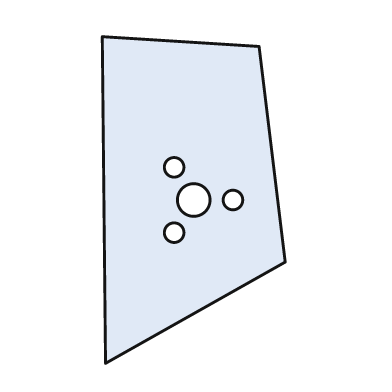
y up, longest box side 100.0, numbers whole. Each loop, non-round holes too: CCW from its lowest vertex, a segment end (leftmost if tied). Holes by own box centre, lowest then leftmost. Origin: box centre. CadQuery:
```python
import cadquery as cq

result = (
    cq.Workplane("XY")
    .moveTo(-27.0, -50.0)
    .lineTo(28.0, -19.0)
    .lineTo(20.0, 47.0)
    .lineTo(-28.0, 50.0)
    .close()
    .moveTo(-6.0, -10.0)
    .circle(3.0)
    .moveTo(0.0, 0.0)
    .circle(5.0)
    .moveTo(12.0, 0.0)
    .circle(3.0)
    .moveTo(-6.0, 10.0)
    .circle(3.0)
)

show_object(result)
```